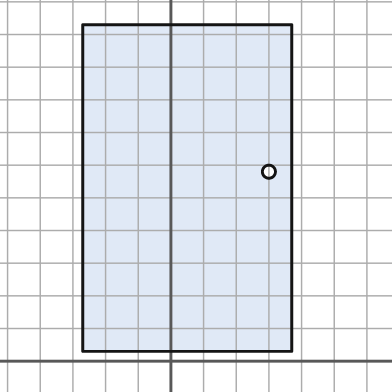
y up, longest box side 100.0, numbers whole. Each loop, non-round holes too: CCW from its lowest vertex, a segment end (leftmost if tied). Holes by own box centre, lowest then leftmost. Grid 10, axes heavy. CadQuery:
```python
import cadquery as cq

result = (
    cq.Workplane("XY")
    .moveTo(-27.0, 3.0)
    .lineTo(37.0, 3.0)
    .lineTo(37.0, 103.0)
    .lineTo(-27.0, 103.0)
    .close()
    .moveTo(30.0, 58.0)
    .circle(2.0)
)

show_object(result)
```